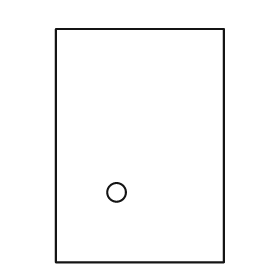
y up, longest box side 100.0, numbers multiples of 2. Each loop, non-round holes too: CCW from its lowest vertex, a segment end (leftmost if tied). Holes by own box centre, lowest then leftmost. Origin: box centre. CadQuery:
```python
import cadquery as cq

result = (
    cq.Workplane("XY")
    .moveTo(-36.0, -50.0)
    .lineTo(36.0, -50.0)
    .lineTo(36.0, 50.0)
    .lineTo(-36.0, 50.0)
    .close()
    .moveTo(-10.0, -20.0)
    .circle(4.0)
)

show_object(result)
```